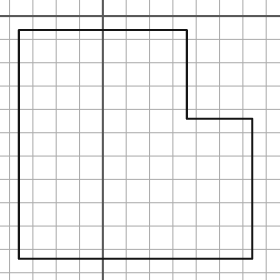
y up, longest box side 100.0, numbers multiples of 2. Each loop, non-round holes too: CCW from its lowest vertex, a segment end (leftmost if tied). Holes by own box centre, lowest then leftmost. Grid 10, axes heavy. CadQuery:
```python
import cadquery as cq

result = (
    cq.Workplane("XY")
    .moveTo(-36.0, -104.0)
    .lineTo(64.0, -104.0)
    .lineTo(64.0, -44.0)
    .lineTo(36.0, -44.0)
    .lineTo(36.0, -6.0)
    .lineTo(-36.0, -6.0)
    .close()
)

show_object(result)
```